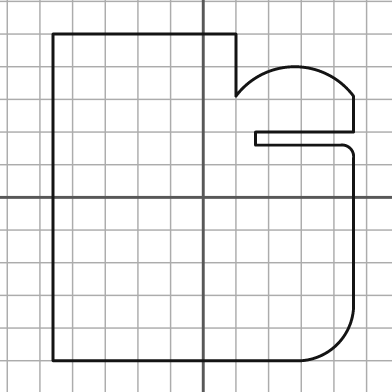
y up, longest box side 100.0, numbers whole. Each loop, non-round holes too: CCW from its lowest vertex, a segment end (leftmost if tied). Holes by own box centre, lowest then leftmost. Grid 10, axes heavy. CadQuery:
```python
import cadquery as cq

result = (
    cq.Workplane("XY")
    .moveTo(-46.0, -50.0)
    .lineTo(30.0, -50.0)
    .threePointArc((41.0, -45.0), (46.0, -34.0))
    .lineTo(46.0, 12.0)
    .threePointArc((45.0, 15.0), (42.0, 16.0))
    .lineTo(16.0, 16.0)
    .lineTo(16.0, 20.0)
    .lineTo(46.0, 20.0)
    .lineTo(46.0, 31.0)
    .threePointArc((28.0, 40.0), (10.0, 31.0))
    .lineTo(10.0, 50.0)
    .lineTo(-46.0, 50.0)
    .close()
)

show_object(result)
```